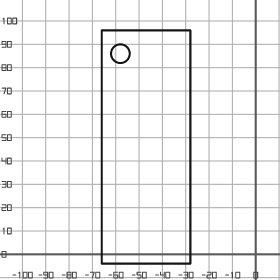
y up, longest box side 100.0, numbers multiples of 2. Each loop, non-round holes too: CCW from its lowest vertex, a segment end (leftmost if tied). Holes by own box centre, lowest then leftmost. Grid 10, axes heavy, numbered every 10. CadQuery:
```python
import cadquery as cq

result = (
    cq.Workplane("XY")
    .moveTo(-66.0, -4.0)
    .lineTo(-28.0, -4.0)
    .lineTo(-28.0, 96.0)
    .lineTo(-66.0, 96.0)
    .close()
    .moveTo(-58.0, 86.0)
    .circle(4.0)
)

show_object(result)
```